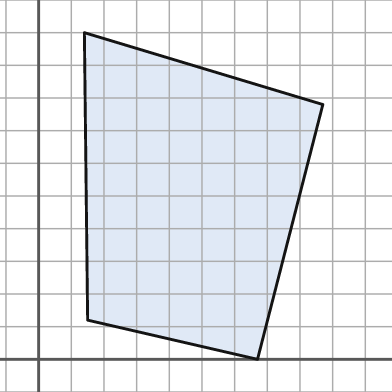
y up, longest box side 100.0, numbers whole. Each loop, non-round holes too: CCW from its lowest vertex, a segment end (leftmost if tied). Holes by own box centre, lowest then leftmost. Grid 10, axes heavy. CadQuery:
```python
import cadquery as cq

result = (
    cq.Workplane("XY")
    .moveTo(67.0, 0.0)
    .lineTo(87.0, 78.0)
    .lineTo(14.0, 100.0)
    .lineTo(15.0, 12.0)
    .close()
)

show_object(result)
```